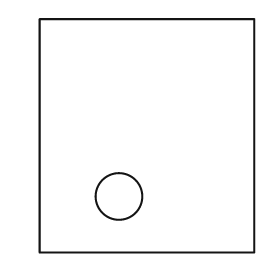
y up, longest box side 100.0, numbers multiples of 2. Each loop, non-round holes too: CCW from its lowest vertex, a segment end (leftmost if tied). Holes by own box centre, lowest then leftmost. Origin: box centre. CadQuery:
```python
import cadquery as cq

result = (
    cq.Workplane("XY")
    .moveTo(-46.0, -50.0)
    .lineTo(46.0, -50.0)
    .lineTo(46.0, 50.0)
    .lineTo(-46.0, 50.0)
    .close()
    .moveTo(-12.0, -26.0)
    .circle(10.0)
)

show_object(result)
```